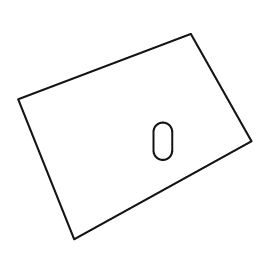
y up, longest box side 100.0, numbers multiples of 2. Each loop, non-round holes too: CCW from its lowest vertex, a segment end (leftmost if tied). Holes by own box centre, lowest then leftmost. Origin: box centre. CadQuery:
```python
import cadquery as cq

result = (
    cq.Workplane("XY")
    .moveTo(-26.0, -44.0)
    .lineTo(50.0, -2.0)
    .lineTo(24.0, 44.0)
    .lineTo(-50.0, 16.0)
    .close()
    .moveTo(8.0, -6.0)
    .threePointArc((12.0, -10.0), (16.0, -6.0))
    .lineTo(16.0, 2.0)
    .threePointArc((12.0, 6.0), (8.0, 2.0))
    .close()
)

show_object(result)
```